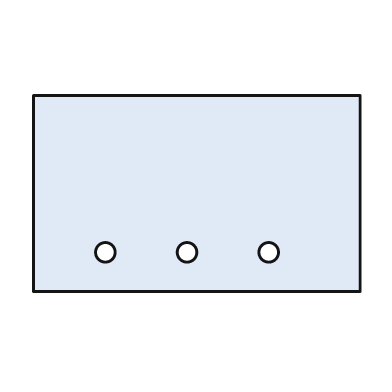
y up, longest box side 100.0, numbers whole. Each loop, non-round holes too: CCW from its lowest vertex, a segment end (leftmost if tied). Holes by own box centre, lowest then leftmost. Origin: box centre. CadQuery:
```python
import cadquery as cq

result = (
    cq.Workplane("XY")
    .moveTo(-50.0, -30.0)
    .lineTo(50.0, -30.0)
    .lineTo(50.0, 30.0)
    .lineTo(-50.0, 30.0)
    .close()
    .moveTo(-28.0, -18.0)
    .circle(3.0)
    .moveTo(-3.0, -18.0)
    .circle(3.0)
    .moveTo(22.0, -18.0)
    .circle(3.0)
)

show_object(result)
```